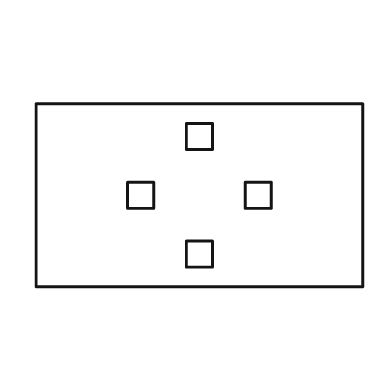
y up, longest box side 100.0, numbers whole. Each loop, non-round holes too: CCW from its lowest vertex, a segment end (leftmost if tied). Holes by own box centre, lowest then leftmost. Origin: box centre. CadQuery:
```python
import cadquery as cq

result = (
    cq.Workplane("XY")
    .moveTo(-50.0, -28.0)
    .lineTo(50.0, -28.0)
    .lineTo(50.0, 28.0)
    .lineTo(-50.0, 28.0)
    .close()
    .moveTo(-4.0, -22.0)
    .lineTo(4.0, -22.0)
    .lineTo(4.0, -14.0)
    .lineTo(-4.0, -14.0)
    .close()
    .moveTo(-22.0, -4.0)
    .lineTo(-14.0, -4.0)
    .lineTo(-14.0, 4.0)
    .lineTo(-22.0, 4.0)
    .close()
    .moveTo(14.0, -4.0)
    .lineTo(22.0, -4.0)
    .lineTo(22.0, 4.0)
    .lineTo(14.0, 4.0)
    .close()
    .moveTo(-4.0, 14.0)
    .lineTo(4.0, 14.0)
    .lineTo(4.0, 22.0)
    .lineTo(-4.0, 22.0)
    .close()
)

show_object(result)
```